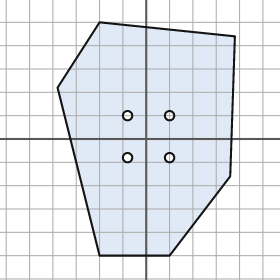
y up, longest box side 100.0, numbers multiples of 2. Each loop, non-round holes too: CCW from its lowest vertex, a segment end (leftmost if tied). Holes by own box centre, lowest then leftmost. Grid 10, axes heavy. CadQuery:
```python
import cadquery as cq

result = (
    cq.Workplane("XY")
    .moveTo(-20.0, -50.0)
    .lineTo(10.0, -50.0)
    .lineTo(36.0, -16.0)
    .lineTo(38.0, 44.0)
    .lineTo(-20.0, 50.0)
    .lineTo(-38.0, 22.0)
    .close()
    .moveTo(-8.0, -8.0)
    .circle(2.0)
    .moveTo(10.0, -8.0)
    .circle(2.0)
    .moveTo(-8.0, 10.0)
    .circle(2.0)
    .moveTo(10.0, 10.0)
    .circle(2.0)
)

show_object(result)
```